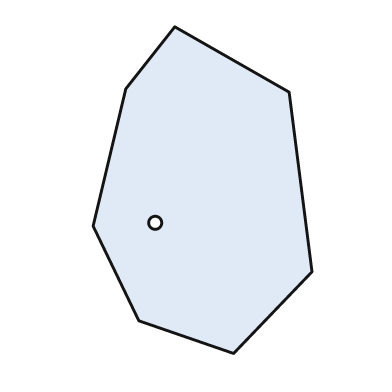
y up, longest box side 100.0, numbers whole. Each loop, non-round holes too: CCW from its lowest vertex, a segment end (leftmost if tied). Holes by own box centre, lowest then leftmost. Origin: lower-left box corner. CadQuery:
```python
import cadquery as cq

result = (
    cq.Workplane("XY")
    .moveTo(43.0, 0.0)
    .lineTo(67.0, 25.0)
    .lineTo(60.0, 80.0)
    .lineTo(25.0, 100.0)
    .lineTo(10.0, 81.0)
    .lineTo(0.0, 39.0)
    .lineTo(14.0, 10.0)
    .close()
    .moveTo(19.0, 40.0)
    .circle(2.0)
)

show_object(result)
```